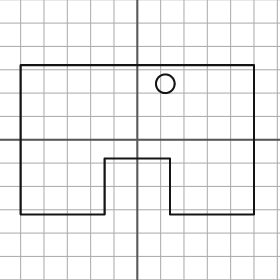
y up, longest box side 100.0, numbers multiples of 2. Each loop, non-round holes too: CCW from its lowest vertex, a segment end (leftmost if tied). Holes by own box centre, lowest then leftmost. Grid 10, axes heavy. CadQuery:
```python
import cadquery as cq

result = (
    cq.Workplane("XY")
    .moveTo(-50.0, -32.0)
    .lineTo(-14.0, -32.0)
    .lineTo(-14.0, -8.0)
    .lineTo(14.0, -8.0)
    .lineTo(14.0, -32.0)
    .lineTo(50.0, -32.0)
    .lineTo(50.0, 32.0)
    .lineTo(-50.0, 32.0)
    .close()
    .moveTo(12.0, 24.0)
    .circle(4.0)
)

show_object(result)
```